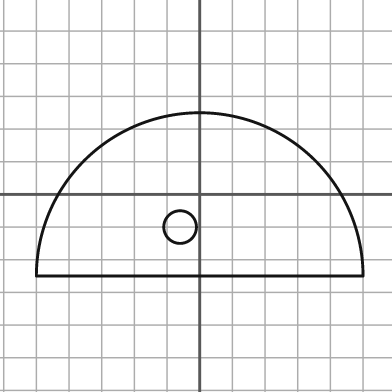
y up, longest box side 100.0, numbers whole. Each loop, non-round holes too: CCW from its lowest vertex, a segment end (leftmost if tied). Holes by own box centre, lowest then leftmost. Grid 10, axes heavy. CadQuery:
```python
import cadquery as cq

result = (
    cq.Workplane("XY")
    .moveTo(-50.0, -25.0)
    .lineTo(50.0, -25.0)
    .threePointArc((0.0, 25.0), (-50.0, -25.0))
    .close()
    .moveTo(-6.0, -10.0)
    .circle(5.0)
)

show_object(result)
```